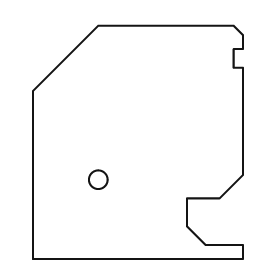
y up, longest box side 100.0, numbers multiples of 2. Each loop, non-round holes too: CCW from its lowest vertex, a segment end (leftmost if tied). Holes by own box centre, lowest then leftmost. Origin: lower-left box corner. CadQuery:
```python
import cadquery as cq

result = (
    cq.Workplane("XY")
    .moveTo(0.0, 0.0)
    .lineTo(90.0, 0.0)
    .lineTo(90.0, 6.0)
    .lineTo(74.0, 6.0)
    .lineTo(66.0, 14.0)
    .lineTo(66.0, 26.0)
    .lineTo(80.0, 26.0)
    .lineTo(90.0, 36.0)
    .lineTo(90.0, 82.0)
    .lineTo(86.0, 82.0)
    .lineTo(86.0, 90.0)
    .lineTo(90.0, 90.0)
    .lineTo(90.0, 96.0)
    .lineTo(86.0, 100.0)
    .lineTo(28.0, 100.0)
    .lineTo(0.0, 72.0)
    .close()
    .moveTo(28.0, 34.0)
    .circle(4.0)
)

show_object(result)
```